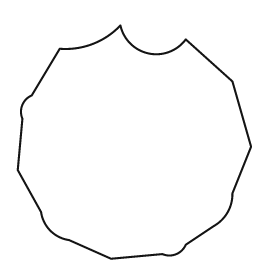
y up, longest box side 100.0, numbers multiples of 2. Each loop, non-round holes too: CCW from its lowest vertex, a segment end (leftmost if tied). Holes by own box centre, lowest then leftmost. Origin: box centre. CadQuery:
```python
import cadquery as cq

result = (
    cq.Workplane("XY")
    .moveTo(-10.0, -50.0)
    .lineTo(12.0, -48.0)
    .threePointArc((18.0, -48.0), (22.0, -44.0))
    .lineTo(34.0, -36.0)
    .threePointArc((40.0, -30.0), (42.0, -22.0))
    .lineTo(50.0, -2.0)
    .lineTo(42.0, 26.0)
    .lineTo(22.0, 44.0)
    .threePointArc((6.0, 38.0), (-6.0, 50.0))
    .threePointArc((-18.0, 42.0), (-32.0, 40.0))
    .lineTo(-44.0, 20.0)
    .threePointArc((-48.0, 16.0), (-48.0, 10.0))
    .lineTo(-50.0, -12.0)
    .lineTo(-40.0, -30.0)
    .threePointArc((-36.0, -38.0), (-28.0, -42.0))
    .close()
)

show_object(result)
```